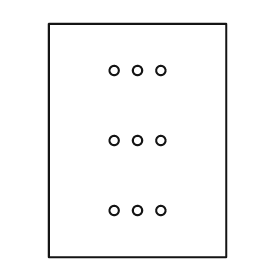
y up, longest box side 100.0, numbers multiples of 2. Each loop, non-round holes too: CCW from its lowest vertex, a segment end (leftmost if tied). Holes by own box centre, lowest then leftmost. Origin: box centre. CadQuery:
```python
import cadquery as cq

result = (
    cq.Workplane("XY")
    .moveTo(-38.0, -50.0)
    .lineTo(38.0, -50.0)
    .lineTo(38.0, 50.0)
    .lineTo(-38.0, 50.0)
    .close()
    .moveTo(-10.0, -30.0)
    .circle(2.0)
    .moveTo(0.0, -30.0)
    .circle(2.0)
    .moveTo(10.0, -30.0)
    .circle(2.0)
    .moveTo(-10.0, 0.0)
    .circle(2.0)
    .moveTo(0.0, 0.0)
    .circle(2.0)
    .moveTo(10.0, 0.0)
    .circle(2.0)
    .moveTo(-10.0, 30.0)
    .circle(2.0)
    .moveTo(0.0, 30.0)
    .circle(2.0)
    .moveTo(10.0, 30.0)
    .circle(2.0)
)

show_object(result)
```